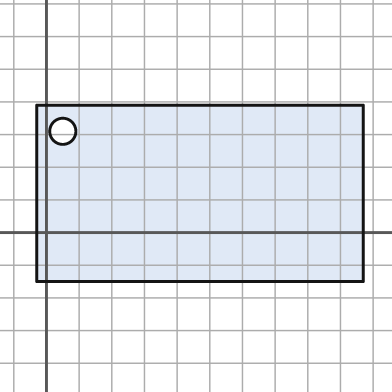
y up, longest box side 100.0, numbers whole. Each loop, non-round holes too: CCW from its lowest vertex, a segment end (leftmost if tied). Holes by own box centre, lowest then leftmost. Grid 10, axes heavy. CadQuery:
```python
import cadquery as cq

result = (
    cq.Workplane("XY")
    .moveTo(-3.0, -15.0)
    .lineTo(97.0, -15.0)
    .lineTo(97.0, 39.0)
    .lineTo(-3.0, 39.0)
    .close()
    .moveTo(5.0, 31.0)
    .circle(4.0)
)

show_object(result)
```